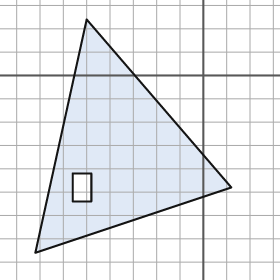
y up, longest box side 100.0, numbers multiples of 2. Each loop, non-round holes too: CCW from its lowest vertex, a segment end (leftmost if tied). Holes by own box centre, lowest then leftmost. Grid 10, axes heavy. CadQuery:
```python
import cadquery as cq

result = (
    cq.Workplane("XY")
    .moveTo(-72.0, -76.0)
    .lineTo(12.0, -48.0)
    .lineTo(-50.0, 24.0)
    .close()
    .moveTo(-56.0, -54.0)
    .lineTo(-48.0, -54.0)
    .lineTo(-48.0, -42.0)
    .lineTo(-56.0, -42.0)
    .close()
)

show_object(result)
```